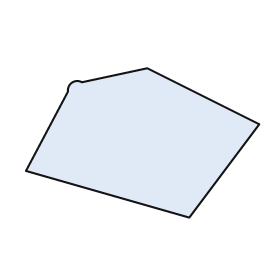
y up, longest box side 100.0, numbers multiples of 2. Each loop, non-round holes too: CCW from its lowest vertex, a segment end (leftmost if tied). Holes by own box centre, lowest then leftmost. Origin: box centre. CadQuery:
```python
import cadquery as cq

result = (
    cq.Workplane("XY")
    .moveTo(20.0, -32.0)
    .lineTo(50.0, 8.0)
    .lineTo(2.0, 32.0)
    .lineTo(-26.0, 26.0)
    .threePointArc((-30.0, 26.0), (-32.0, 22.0))
    .lineTo(-50.0, -12.0)
    .close()
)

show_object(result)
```